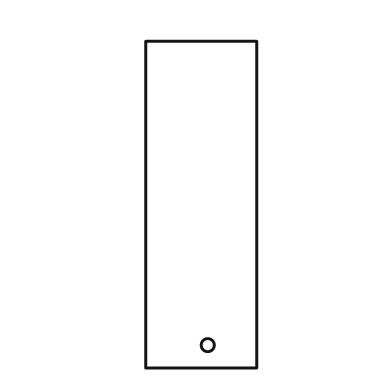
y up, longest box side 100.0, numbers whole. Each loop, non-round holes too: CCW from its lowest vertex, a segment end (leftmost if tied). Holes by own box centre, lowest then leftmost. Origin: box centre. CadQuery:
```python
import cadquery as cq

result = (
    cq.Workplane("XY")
    .moveTo(-17.0, -50.0)
    .lineTo(17.0, -50.0)
    .lineTo(17.0, 50.0)
    .lineTo(-17.0, 50.0)
    .close()
    .moveTo(2.0, -43.0)
    .circle(2.0)
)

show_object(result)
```